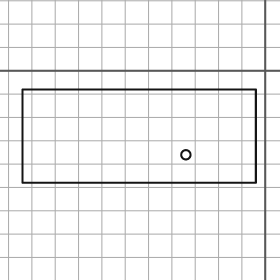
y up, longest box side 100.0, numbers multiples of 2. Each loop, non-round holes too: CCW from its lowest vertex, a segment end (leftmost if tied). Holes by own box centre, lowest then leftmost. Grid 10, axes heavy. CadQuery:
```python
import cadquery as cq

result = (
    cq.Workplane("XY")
    .moveTo(-104.0, -48.0)
    .lineTo(-4.0, -48.0)
    .lineTo(-4.0, -8.0)
    .lineTo(-104.0, -8.0)
    .close()
    .moveTo(-34.0, -36.0)
    .circle(2.0)
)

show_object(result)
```